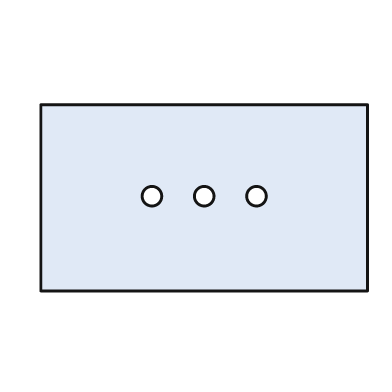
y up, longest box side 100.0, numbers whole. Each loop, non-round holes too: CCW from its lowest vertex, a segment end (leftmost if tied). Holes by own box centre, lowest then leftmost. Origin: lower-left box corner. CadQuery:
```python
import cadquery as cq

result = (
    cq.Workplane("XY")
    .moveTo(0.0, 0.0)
    .lineTo(100.0, 0.0)
    .lineTo(100.0, 57.0)
    .lineTo(0.0, 57.0)
    .close()
    .moveTo(34.0, 29.0)
    .circle(3.0)
    .moveTo(50.0, 29.0)
    .circle(3.0)
    .moveTo(66.0, 29.0)
    .circle(3.0)
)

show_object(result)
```